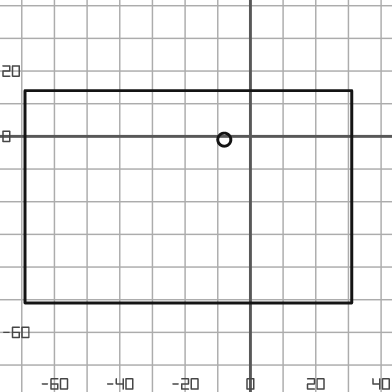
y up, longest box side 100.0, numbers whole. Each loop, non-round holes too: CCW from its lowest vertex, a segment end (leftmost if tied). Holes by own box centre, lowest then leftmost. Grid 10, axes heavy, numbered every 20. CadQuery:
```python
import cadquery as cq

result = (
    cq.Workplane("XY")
    .moveTo(-69.0, -51.0)
    .lineTo(31.0, -51.0)
    .lineTo(31.0, 14.0)
    .lineTo(-69.0, 14.0)
    .close()
    .moveTo(-8.0, -1.0)
    .circle(2.0)
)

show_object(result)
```